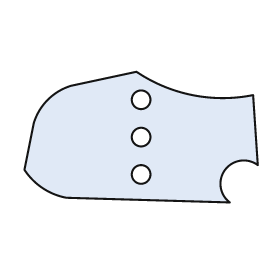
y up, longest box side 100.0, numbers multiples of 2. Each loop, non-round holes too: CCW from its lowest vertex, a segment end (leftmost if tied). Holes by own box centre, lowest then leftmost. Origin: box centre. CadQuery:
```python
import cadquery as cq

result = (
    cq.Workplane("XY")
    .moveTo(38.0, -28.0)
    .threePointArc((36.0, -14.0), (50.0, -12.0))
    .lineTo(48.0, 18.0)
    .threePointArc((22.0, 18.0), (-2.0, 28.0))
    .lineTo(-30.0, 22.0)
    .threePointArc((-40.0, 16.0), (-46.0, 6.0))
    .lineTo(-50.0, -14.0)
    .threePointArc((-42.0, -22.0), (-32.0, -26.0))
    .close()
    .moveTo(0.0, -16.0)
    .circle(4.0)
    .moveTo(0.0, 0.0)
    .circle(4.0)
    .moveTo(0.0, 16.0)
    .circle(4.0)
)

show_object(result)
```